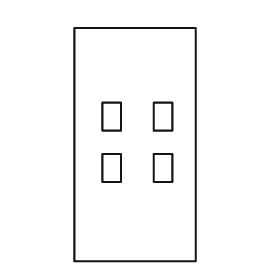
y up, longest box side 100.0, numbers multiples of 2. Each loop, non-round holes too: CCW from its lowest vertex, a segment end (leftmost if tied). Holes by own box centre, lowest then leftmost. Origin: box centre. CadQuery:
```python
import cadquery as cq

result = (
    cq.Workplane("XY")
    .moveTo(-26.0, -50.0)
    .lineTo(26.0, -50.0)
    .lineTo(26.0, 50.0)
    .lineTo(-26.0, 50.0)
    .close()
    .moveTo(-14.0, -16.0)
    .lineTo(-6.0, -16.0)
    .lineTo(-6.0, -4.0)
    .lineTo(-14.0, -4.0)
    .close()
    .moveTo(8.0, -16.0)
    .lineTo(16.0, -16.0)
    .lineTo(16.0, -4.0)
    .lineTo(8.0, -4.0)
    .close()
    .moveTo(-14.0, 6.0)
    .lineTo(-6.0, 6.0)
    .lineTo(-6.0, 18.0)
    .lineTo(-14.0, 18.0)
    .close()
    .moveTo(8.0, 6.0)
    .lineTo(16.0, 6.0)
    .lineTo(16.0, 18.0)
    .lineTo(8.0, 18.0)
    .close()
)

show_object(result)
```